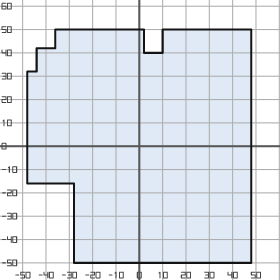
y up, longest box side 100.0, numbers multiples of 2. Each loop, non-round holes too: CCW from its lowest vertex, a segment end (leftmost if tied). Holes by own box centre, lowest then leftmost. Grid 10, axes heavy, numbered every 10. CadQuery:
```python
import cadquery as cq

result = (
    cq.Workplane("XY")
    .moveTo(-28.0, -50.0)
    .lineTo(48.0, -50.0)
    .lineTo(48.0, 50.0)
    .lineTo(10.0, 50.0)
    .lineTo(10.0, 40.0)
    .lineTo(2.0, 40.0)
    .lineTo(2.0, 50.0)
    .lineTo(-36.0, 50.0)
    .lineTo(-36.0, 42.0)
    .lineTo(-44.0, 42.0)
    .lineTo(-44.0, 32.0)
    .lineTo(-48.0, 32.0)
    .lineTo(-48.0, -16.0)
    .lineTo(-28.0, -16.0)
    .close()
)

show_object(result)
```